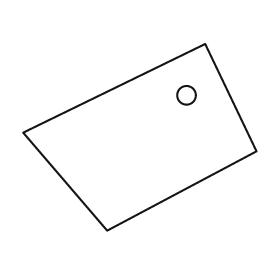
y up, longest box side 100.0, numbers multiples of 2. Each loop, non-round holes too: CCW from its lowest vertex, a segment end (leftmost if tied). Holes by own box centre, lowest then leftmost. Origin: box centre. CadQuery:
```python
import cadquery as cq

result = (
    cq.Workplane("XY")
    .moveTo(-14.0, -40.0)
    .lineTo(50.0, -6.0)
    .lineTo(28.0, 40.0)
    .lineTo(-50.0, 2.0)
    .close()
    .moveTo(20.0, 18.0)
    .circle(4.0)
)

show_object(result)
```